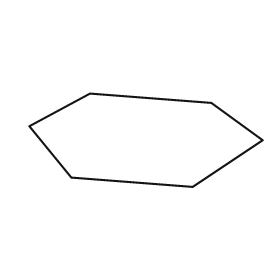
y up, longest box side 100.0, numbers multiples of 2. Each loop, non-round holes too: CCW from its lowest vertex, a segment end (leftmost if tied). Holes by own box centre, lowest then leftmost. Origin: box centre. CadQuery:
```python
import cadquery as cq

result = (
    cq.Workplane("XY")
    .moveTo(20.0, -20.0)
    .lineTo(50.0, 0.0)
    .lineTo(28.0, 16.0)
    .lineTo(-24.0, 20.0)
    .lineTo(-50.0, 6.0)
    .lineTo(-32.0, -16.0)
    .close()
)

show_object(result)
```